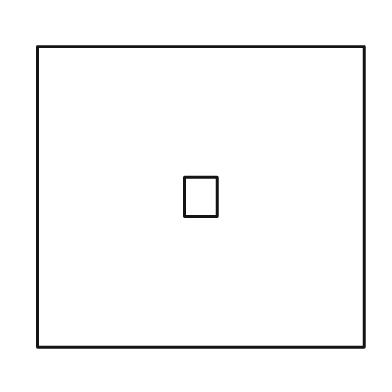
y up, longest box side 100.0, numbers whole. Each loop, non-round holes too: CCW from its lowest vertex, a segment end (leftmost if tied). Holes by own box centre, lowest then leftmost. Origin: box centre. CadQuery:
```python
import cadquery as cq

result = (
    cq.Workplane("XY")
    .moveTo(-50.0, -46.0)
    .lineTo(50.0, -46.0)
    .lineTo(50.0, 46.0)
    .lineTo(-50.0, 46.0)
    .close()
    .moveTo(-5.0, -6.0)
    .lineTo(5.0, -6.0)
    .lineTo(5.0, 6.0)
    .lineTo(-5.0, 6.0)
    .close()
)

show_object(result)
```